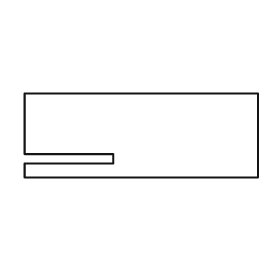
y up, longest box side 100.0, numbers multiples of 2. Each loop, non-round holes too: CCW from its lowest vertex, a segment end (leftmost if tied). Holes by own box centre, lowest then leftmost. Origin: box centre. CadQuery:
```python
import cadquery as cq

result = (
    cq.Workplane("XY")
    .moveTo(-50.0, -18.0)
    .lineTo(50.0, -18.0)
    .lineTo(50.0, 18.0)
    .lineTo(-50.0, 18.0)
    .lineTo(-50.0, -8.0)
    .lineTo(-12.0, -8.0)
    .lineTo(-12.0, -12.0)
    .lineTo(-50.0, -12.0)
    .close()
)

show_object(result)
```